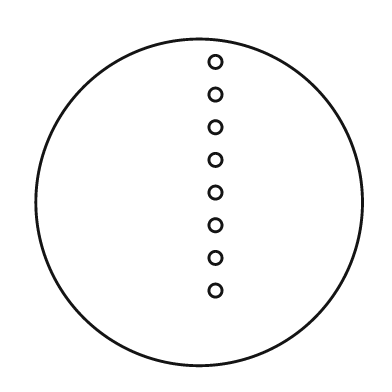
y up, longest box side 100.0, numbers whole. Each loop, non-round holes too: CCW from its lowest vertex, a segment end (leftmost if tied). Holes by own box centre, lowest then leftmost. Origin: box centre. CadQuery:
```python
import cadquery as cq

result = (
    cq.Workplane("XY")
    .moveTo(0.0, 0.0)
    .circle(50.0)
    .moveTo(5.0, -27.0)
    .circle(2.0)
    .moveTo(5.0, -17.0)
    .circle(2.0)
    .moveTo(5.0, -7.0)
    .circle(2.0)
    .moveTo(5.0, 3.0)
    .circle(2.0)
    .moveTo(5.0, 13.0)
    .circle(2.0)
    .moveTo(5.0, 23.0)
    .circle(2.0)
    .moveTo(5.0, 33.0)
    .circle(2.0)
    .moveTo(5.0, 43.0)
    .circle(2.0)
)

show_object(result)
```